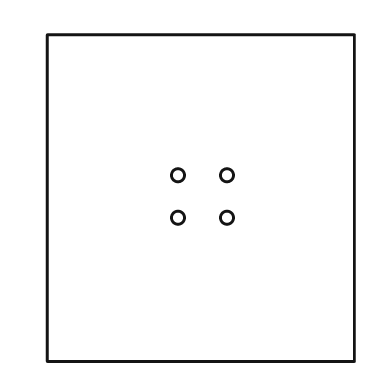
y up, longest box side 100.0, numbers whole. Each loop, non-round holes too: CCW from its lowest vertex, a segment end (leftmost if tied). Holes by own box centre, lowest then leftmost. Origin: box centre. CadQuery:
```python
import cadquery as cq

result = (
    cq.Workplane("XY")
    .moveTo(-47.0, -50.0)
    .lineTo(47.0, -50.0)
    .lineTo(47.0, 50.0)
    .lineTo(-47.0, 50.0)
    .close()
    .moveTo(-7.0, -6.0)
    .circle(2.0)
    .moveTo(8.0, -6.0)
    .circle(2.0)
    .moveTo(-7.0, 7.0)
    .circle(2.0)
    .moveTo(8.0, 7.0)
    .circle(2.0)
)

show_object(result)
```